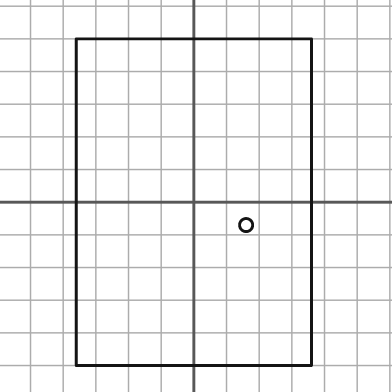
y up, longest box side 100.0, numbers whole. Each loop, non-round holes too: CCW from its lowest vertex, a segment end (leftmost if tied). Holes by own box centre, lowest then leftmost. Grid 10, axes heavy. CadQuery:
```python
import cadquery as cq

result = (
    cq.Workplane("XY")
    .moveTo(-36.0, -50.0)
    .lineTo(36.0, -50.0)
    .lineTo(36.0, 50.0)
    .lineTo(-36.0, 50.0)
    .close()
    .moveTo(16.0, -7.0)
    .circle(2.0)
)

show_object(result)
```